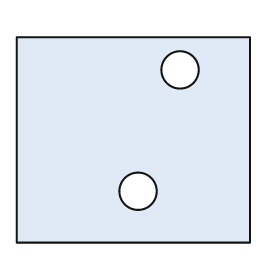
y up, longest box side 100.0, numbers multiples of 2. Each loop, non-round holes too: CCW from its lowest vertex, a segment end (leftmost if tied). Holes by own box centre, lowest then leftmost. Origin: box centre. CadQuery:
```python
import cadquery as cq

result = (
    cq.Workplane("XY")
    .moveTo(-50.0, -44.0)
    .lineTo(50.0, -44.0)
    .lineTo(50.0, 44.0)
    .lineTo(-50.0, 44.0)
    .close()
    .moveTo(2.0, -22.0)
    .circle(8.0)
    .moveTo(20.0, 30.0)
    .circle(8.0)
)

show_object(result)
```